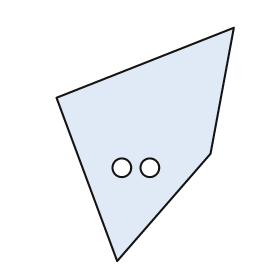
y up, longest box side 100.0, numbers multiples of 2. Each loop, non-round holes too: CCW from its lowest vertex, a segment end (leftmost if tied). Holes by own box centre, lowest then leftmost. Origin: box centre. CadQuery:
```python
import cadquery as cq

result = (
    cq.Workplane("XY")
    .moveTo(-12.0, -50.0)
    .lineTo(28.0, -4.0)
    .lineTo(38.0, 50.0)
    .lineTo(-38.0, 20.0)
    .close()
    .moveTo(-10.0, -10.0)
    .circle(4.0)
    .moveTo(2.0, -10.0)
    .circle(4.0)
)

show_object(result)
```